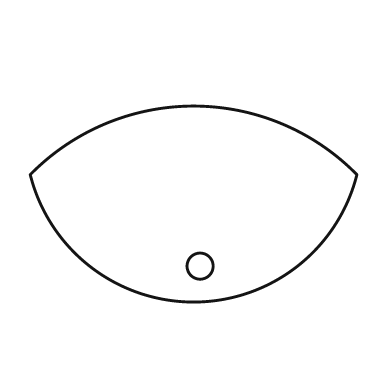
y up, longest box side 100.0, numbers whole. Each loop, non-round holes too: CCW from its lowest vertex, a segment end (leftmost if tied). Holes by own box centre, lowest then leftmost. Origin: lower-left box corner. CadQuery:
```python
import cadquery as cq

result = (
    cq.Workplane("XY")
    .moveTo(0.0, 39.0)
    .threePointArc((50.0, 0.0), (100.0, 39.0))
    .threePointArc((50.0, 60.0), (0.0, 39.0))
    .close()
    .moveTo(52.0, 11.0)
    .circle(4.0)
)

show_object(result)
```